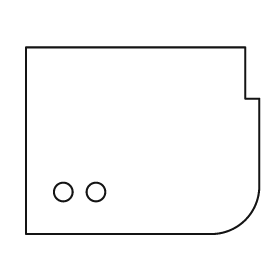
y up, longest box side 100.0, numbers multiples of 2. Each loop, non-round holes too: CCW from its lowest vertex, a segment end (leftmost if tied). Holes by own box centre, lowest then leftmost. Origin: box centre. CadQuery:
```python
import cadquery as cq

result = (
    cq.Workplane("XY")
    .moveTo(-50.0, -40.0)
    .lineTo(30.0, -40.0)
    .threePointArc((44.0, -34.0), (50.0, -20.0))
    .lineTo(50.0, 18.0)
    .lineTo(44.0, 18.0)
    .lineTo(44.0, 40.0)
    .lineTo(-50.0, 40.0)
    .close()
    .moveTo(-34.0, -22.0)
    .circle(4.0)
    .moveTo(-20.0, -22.0)
    .circle(4.0)
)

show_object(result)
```